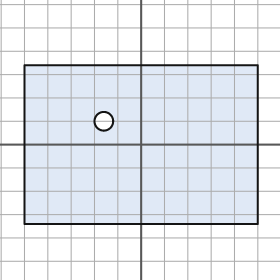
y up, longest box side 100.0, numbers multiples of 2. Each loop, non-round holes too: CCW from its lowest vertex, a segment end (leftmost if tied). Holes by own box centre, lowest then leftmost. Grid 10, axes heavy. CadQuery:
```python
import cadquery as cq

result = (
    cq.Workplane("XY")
    .moveTo(-50.0, -34.0)
    .lineTo(50.0, -34.0)
    .lineTo(50.0, 34.0)
    .lineTo(-50.0, 34.0)
    .close()
    .moveTo(-16.0, 10.0)
    .circle(4.0)
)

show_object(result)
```